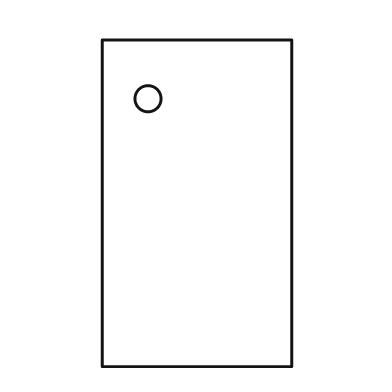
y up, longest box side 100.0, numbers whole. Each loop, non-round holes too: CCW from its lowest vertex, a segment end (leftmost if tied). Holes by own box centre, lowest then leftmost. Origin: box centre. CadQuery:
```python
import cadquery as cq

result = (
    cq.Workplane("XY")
    .moveTo(-29.0, -50.0)
    .lineTo(29.0, -50.0)
    .lineTo(29.0, 50.0)
    .lineTo(-29.0, 50.0)
    .close()
    .moveTo(-15.0, 32.0)
    .circle(4.0)
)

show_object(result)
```